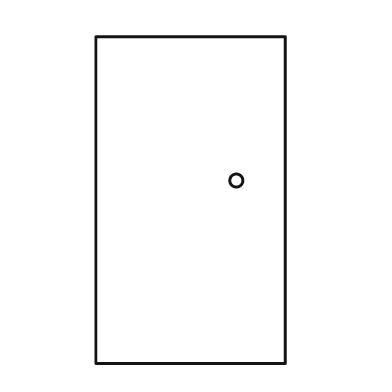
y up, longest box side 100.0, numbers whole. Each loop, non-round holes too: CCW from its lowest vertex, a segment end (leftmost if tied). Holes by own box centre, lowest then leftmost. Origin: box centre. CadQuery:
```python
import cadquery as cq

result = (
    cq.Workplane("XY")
    .moveTo(-29.0, -50.0)
    .lineTo(29.0, -50.0)
    .lineTo(29.0, 50.0)
    .lineTo(-29.0, 50.0)
    .close()
    .moveTo(14.0, 6.0)
    .circle(2.0)
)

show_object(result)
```